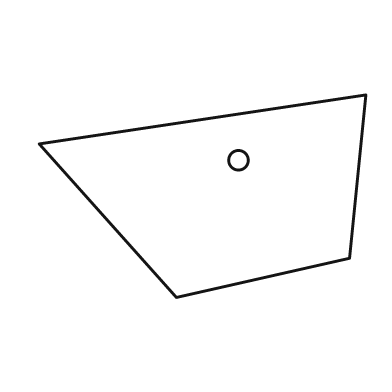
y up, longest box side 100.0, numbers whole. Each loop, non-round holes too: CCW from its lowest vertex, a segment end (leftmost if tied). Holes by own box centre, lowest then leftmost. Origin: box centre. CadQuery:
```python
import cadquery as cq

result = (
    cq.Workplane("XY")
    .moveTo(-8.0, -31.0)
    .lineTo(45.0, -19.0)
    .lineTo(50.0, 31.0)
    .lineTo(-50.0, 16.0)
    .close()
    .moveTo(11.0, 11.0)
    .circle(3.0)
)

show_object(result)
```